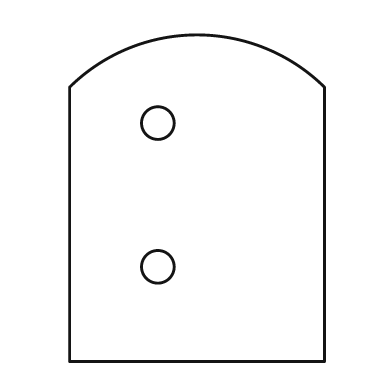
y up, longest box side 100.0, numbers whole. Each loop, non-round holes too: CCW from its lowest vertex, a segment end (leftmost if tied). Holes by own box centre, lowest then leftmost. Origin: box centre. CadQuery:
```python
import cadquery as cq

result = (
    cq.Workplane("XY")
    .moveTo(-39.0, -50.0)
    .lineTo(39.0, -50.0)
    .lineTo(39.0, 34.0)
    .threePointArc((0.0, 50.0), (-39.0, 34.0))
    .close()
    .moveTo(-12.0, -21.0)
    .circle(5.0)
    .moveTo(-12.0, 23.0)
    .circle(5.0)
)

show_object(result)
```